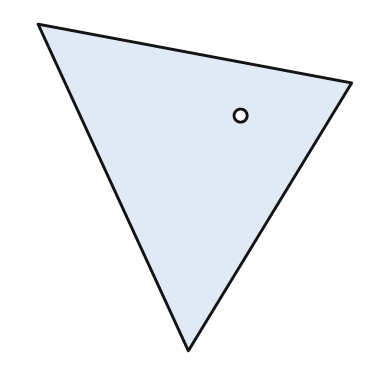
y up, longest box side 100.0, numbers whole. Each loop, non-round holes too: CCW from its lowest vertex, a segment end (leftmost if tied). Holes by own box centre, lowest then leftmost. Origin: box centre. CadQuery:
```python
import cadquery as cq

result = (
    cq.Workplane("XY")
    .moveTo(-2.0, -50.0)
    .lineTo(48.0, 32.0)
    .lineTo(-48.0, 50.0)
    .close()
    .moveTo(14.0, 22.0)
    .circle(2.0)
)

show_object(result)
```